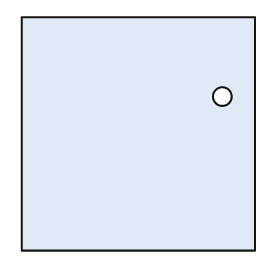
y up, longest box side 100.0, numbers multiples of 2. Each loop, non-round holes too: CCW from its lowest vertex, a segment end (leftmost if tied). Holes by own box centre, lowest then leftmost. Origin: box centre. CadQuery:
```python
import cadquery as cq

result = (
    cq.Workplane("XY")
    .moveTo(-50.0, -50.0)
    .lineTo(50.0, -50.0)
    .lineTo(50.0, 50.0)
    .lineTo(-50.0, 50.0)
    .close()
    .moveTo(36.0, 16.0)
    .circle(4.0)
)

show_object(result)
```